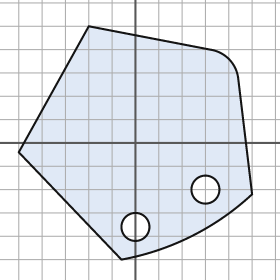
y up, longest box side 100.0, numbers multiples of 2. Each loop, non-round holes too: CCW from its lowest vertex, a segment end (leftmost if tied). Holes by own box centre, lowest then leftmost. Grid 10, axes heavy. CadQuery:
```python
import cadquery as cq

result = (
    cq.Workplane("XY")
    .moveTo(-6.0, -50.0)
    .threePointArc((24.0, -40.0), (50.0, -22.0))
    .lineTo(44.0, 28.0)
    .threePointArc((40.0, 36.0), (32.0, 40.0))
    .lineTo(-20.0, 50.0)
    .lineTo(-50.0, -4.0)
    .close()
    .moveTo(0.0, -36.0)
    .circle(6.0)
    .moveTo(30.0, -20.0)
    .circle(6.0)
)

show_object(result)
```